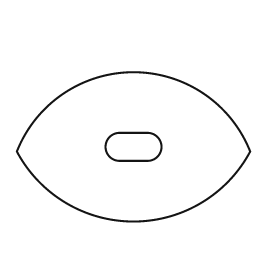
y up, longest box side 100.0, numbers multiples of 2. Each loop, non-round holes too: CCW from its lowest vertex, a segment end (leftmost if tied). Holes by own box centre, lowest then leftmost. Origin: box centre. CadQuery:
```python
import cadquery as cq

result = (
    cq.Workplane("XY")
    .moveTo(-50.0, -2.0)
    .threePointArc((0.0, -32.0), (50.0, -2.0))
    .threePointArc((0.0, 32.0), (-50.0, -2.0))
    .close()
    .moveTo(-6.0, -6.0)
    .lineTo(6.0, -6.0)
    .threePointArc((12.0, 0.0), (6.0, 6.0))
    .lineTo(-6.0, 6.0)
    .threePointArc((-12.0, 0.0), (-6.0, -6.0))
    .close()
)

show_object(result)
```